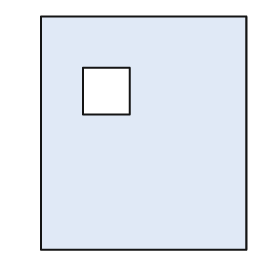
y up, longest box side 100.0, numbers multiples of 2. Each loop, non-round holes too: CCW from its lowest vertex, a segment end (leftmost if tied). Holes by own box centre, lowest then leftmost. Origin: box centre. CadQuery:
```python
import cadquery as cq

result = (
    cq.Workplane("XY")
    .moveTo(-44.0, -50.0)
    .lineTo(44.0, -50.0)
    .lineTo(44.0, 50.0)
    .lineTo(-44.0, 50.0)
    .close()
    .moveTo(-26.0, 8.0)
    .lineTo(-6.0, 8.0)
    .lineTo(-6.0, 28.0)
    .lineTo(-26.0, 28.0)
    .close()
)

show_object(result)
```